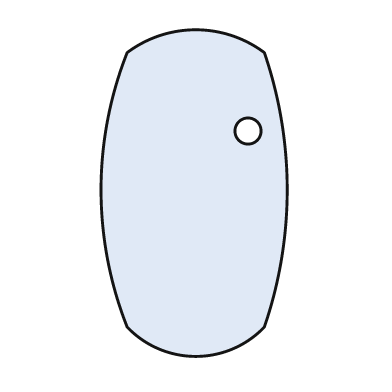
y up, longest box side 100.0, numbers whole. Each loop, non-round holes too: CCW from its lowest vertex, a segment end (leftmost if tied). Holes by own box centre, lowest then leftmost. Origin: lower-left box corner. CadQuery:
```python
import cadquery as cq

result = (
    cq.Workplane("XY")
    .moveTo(8.0, 9.0)
    .threePointArc((29.0, 0.0), (50.0, 9.0))
    .threePointArc((57.0, 51.0), (50.0, 93.0))
    .threePointArc((29.0, 100.0), (8.0, 93.0))
    .threePointArc((0.0, 51.0), (8.0, 9.0))
    .close()
    .moveTo(45.0, 69.0)
    .circle(4.0)
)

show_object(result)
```